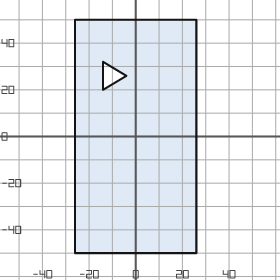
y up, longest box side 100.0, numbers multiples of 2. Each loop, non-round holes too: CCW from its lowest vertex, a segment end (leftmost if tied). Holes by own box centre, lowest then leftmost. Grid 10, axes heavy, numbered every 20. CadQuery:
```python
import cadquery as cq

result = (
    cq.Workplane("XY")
    .moveTo(-26.0, -50.0)
    .lineTo(26.0, -50.0)
    .lineTo(26.0, 50.0)
    .lineTo(-26.0, 50.0)
    .close()
    .moveTo(-14.0, 20.0)
    .lineTo(-4.0, 26.0)
    .lineTo(-14.0, 32.0)
    .close()
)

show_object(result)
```